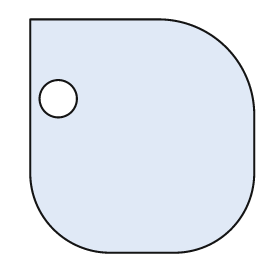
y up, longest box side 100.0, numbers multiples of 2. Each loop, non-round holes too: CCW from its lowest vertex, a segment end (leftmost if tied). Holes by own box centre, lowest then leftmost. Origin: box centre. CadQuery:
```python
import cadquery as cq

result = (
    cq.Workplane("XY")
    .moveTo(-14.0, -50.0)
    .lineTo(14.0, -50.0)
    .threePointArc((38.0, -40.0), (48.0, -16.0))
    .lineTo(48.0, 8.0)
    .threePointArc((36.0, 38.0), (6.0, 50.0))
    .lineTo(-48.0, 50.0)
    .lineTo(-48.0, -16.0)
    .threePointArc((-38.0, -40.0), (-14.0, -50.0))
    .close()
    .moveTo(-36.0, 16.0)
    .circle(8.0)
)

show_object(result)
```